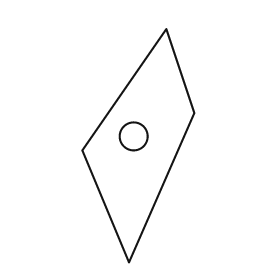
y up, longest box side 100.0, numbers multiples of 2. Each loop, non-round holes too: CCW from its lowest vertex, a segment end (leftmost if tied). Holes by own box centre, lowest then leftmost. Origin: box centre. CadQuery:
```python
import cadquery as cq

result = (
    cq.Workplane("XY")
    .moveTo(-4.0, -50.0)
    .lineTo(24.0, 14.0)
    .lineTo(12.0, 50.0)
    .lineTo(-24.0, -2.0)
    .close()
    .moveTo(-2.0, 4.0)
    .circle(6.0)
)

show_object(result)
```